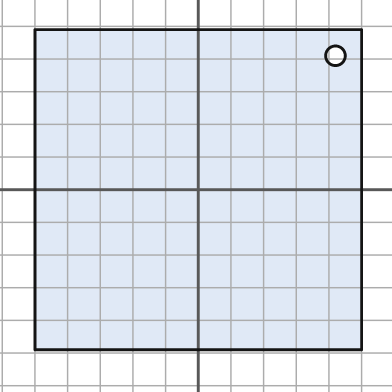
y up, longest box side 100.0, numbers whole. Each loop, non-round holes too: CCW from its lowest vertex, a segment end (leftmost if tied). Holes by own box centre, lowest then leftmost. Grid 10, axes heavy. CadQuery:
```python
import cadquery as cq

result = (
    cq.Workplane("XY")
    .moveTo(-50.0, -49.0)
    .lineTo(50.0, -49.0)
    .lineTo(50.0, 49.0)
    .lineTo(-50.0, 49.0)
    .close()
    .moveTo(42.0, 41.0)
    .circle(3.0)
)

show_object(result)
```